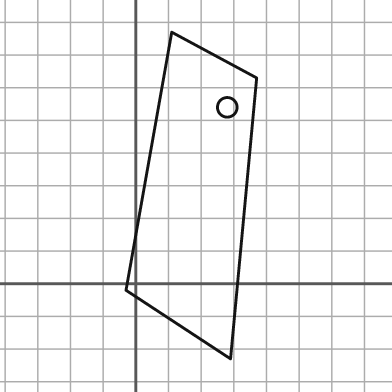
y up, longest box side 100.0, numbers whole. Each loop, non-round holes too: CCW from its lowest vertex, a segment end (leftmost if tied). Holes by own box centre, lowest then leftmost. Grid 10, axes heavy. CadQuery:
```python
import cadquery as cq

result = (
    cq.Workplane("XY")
    .moveTo(29.0, -23.0)
    .lineTo(37.0, 63.0)
    .lineTo(11.0, 77.0)
    .lineTo(-3.0, -2.0)
    .close()
    .moveTo(28.0, 54.0)
    .circle(3.0)
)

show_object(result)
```